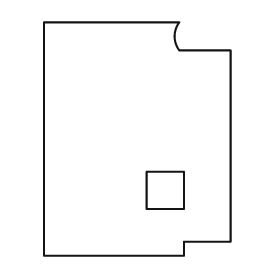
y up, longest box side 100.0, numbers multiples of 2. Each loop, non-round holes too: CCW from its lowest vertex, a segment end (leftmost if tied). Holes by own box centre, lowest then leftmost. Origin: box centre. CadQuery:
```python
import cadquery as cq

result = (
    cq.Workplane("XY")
    .moveTo(-40.0, -50.0)
    .lineTo(20.0, -50.0)
    .lineTo(20.0, -44.0)
    .lineTo(40.0, -44.0)
    .lineTo(40.0, 38.0)
    .lineTo(18.0, 38.0)
    .threePointArc((16.0, 44.0), (18.0, 50.0))
    .lineTo(-40.0, 50.0)
    .close()
    .moveTo(4.0, -30.0)
    .lineTo(20.0, -30.0)
    .lineTo(20.0, -14.0)
    .lineTo(4.0, -14.0)
    .close()
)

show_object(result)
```